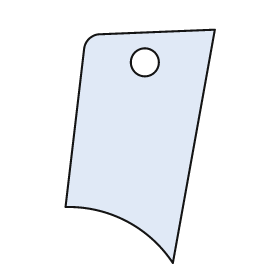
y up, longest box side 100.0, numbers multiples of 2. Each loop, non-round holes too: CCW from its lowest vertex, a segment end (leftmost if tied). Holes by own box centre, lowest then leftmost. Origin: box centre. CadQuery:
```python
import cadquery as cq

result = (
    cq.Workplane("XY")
    .moveTo(14.0, -50.0)
    .lineTo(32.0, 50.0)
    .lineTo(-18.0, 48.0)
    .threePointArc((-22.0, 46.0), (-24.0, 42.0))
    .lineTo(-32.0, -26.0)
    .threePointArc((-6.0, -32.0), (14.0, -50.0))
    .close()
    .moveTo(2.0, 36.0)
    .circle(6.0)
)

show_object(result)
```